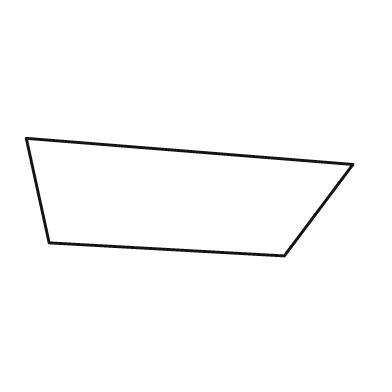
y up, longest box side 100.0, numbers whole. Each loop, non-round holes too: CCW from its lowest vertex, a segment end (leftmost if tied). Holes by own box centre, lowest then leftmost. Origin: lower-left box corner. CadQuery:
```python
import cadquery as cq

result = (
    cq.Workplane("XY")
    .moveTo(79.0, 0.0)
    .lineTo(100.0, 28.0)
    .lineTo(0.0, 36.0)
    .lineTo(7.0, 4.0)
    .close()
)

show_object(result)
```